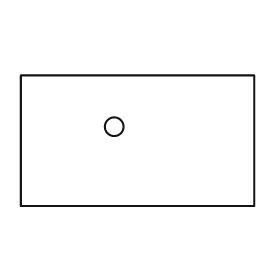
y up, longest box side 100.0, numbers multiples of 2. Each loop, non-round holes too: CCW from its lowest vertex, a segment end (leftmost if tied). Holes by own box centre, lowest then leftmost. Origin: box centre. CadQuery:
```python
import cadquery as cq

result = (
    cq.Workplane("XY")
    .moveTo(-50.0, -28.0)
    .lineTo(50.0, -28.0)
    .lineTo(50.0, 28.0)
    .lineTo(-50.0, 28.0)
    .close()
    .moveTo(-10.0, 6.0)
    .circle(4.0)
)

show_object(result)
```